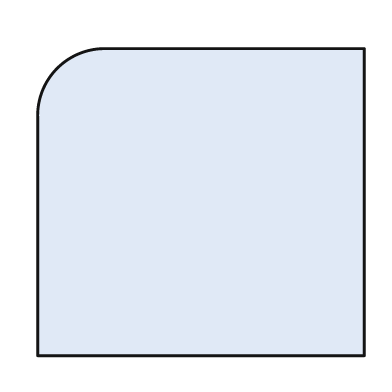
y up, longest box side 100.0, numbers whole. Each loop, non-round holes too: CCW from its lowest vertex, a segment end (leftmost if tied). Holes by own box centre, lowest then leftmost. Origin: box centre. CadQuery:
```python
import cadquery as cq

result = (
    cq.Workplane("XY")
    .moveTo(-50.0, -47.0)
    .lineTo(50.0, -47.0)
    .lineTo(50.0, 47.0)
    .lineTo(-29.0, 47.0)
    .threePointArc((-44.0, 41.0), (-50.0, 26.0))
    .close()
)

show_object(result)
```